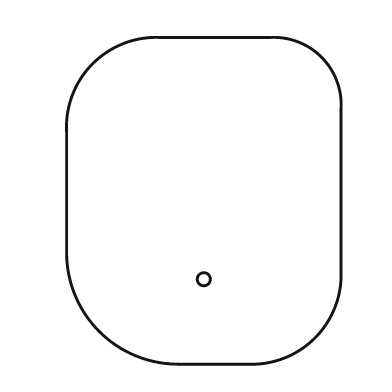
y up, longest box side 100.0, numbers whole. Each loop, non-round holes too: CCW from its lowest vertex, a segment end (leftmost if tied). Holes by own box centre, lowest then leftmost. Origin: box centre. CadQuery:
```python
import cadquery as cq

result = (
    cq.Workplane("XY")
    .moveTo(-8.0, -50.0)
    .lineTo(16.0, -50.0)
    .threePointArc((34.0, -42.0), (42.0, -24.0))
    .lineTo(42.0, 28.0)
    .threePointArc((36.0, 44.0), (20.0, 50.0))
    .lineTo(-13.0, 50.0)
    .threePointArc((-34.0, 42.0), (-42.0, 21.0))
    .lineTo(-42.0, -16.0)
    .threePointArc((-32.0, -40.0), (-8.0, -50.0))
    .close()
    .moveTo(0.0, -24.0)
    .circle(2.0)
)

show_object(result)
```